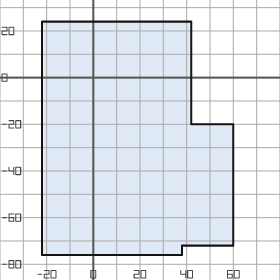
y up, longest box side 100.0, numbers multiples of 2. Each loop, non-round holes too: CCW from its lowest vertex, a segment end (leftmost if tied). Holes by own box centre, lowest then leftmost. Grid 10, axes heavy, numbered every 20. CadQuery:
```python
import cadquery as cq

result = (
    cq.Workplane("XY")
    .moveTo(-22.0, -76.0)
    .lineTo(38.0, -76.0)
    .lineTo(38.0, -72.0)
    .lineTo(60.0, -72.0)
    .lineTo(60.0, -20.0)
    .lineTo(42.0, -20.0)
    .lineTo(42.0, 24.0)
    .lineTo(-22.0, 24.0)
    .close()
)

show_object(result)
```